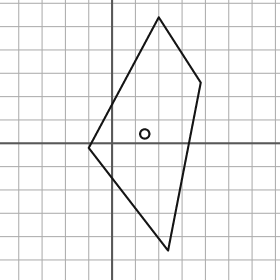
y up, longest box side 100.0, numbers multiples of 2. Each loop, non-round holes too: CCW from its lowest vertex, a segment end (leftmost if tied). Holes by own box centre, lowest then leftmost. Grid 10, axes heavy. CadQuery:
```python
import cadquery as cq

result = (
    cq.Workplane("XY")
    .moveTo(24.0, -46.0)
    .lineTo(38.0, 26.0)
    .lineTo(20.0, 54.0)
    .lineTo(-10.0, -2.0)
    .close()
    .moveTo(14.0, 4.0)
    .circle(2.0)
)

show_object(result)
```